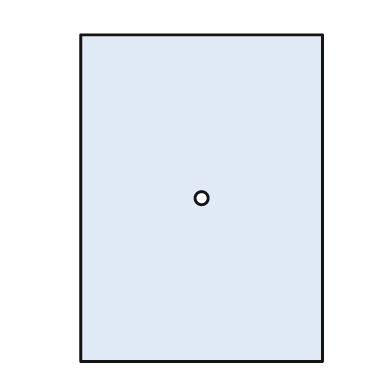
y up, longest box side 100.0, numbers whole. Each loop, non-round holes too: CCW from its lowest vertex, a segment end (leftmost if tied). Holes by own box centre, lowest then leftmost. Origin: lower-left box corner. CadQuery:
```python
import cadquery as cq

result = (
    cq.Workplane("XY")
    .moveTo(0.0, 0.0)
    .lineTo(74.0, 0.0)
    .lineTo(74.0, 100.0)
    .lineTo(0.0, 100.0)
    .close()
    .moveTo(37.0, 50.0)
    .circle(2.0)
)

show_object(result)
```